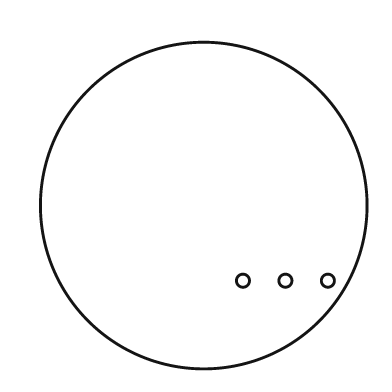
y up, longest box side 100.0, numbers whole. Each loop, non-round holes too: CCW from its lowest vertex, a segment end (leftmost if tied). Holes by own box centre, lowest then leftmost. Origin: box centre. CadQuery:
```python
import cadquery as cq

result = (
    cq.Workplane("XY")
    .moveTo(0.0, 0.0)
    .circle(50.0)
    .moveTo(12.0, -23.0)
    .circle(2.0)
    .moveTo(25.0, -23.0)
    .circle(2.0)
    .moveTo(38.0, -23.0)
    .circle(2.0)
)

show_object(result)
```